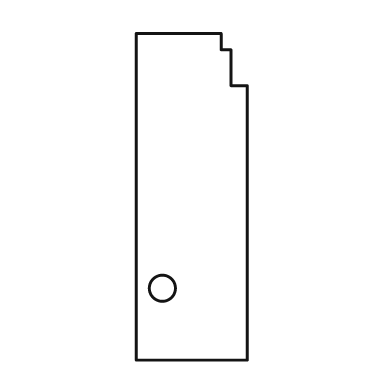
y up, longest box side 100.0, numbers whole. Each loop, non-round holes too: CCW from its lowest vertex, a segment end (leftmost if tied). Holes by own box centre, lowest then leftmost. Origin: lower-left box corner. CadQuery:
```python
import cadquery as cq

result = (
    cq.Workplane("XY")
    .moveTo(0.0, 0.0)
    .lineTo(34.0, 0.0)
    .lineTo(34.0, 84.0)
    .lineTo(29.0, 84.0)
    .lineTo(29.0, 95.0)
    .lineTo(26.0, 95.0)
    .lineTo(26.0, 100.0)
    .lineTo(0.0, 100.0)
    .close()
    .moveTo(8.0, 22.0)
    .circle(4.0)
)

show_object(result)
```